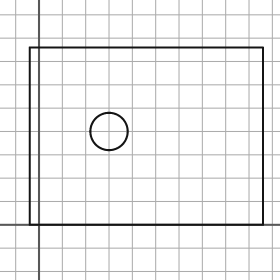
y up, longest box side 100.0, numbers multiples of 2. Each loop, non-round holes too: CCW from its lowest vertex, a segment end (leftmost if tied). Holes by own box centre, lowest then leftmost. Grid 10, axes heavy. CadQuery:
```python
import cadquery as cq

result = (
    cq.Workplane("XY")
    .moveTo(-4.0, 0.0)
    .lineTo(96.0, 0.0)
    .lineTo(96.0, 76.0)
    .lineTo(-4.0, 76.0)
    .close()
    .moveTo(30.0, 40.0)
    .circle(8.0)
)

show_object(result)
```